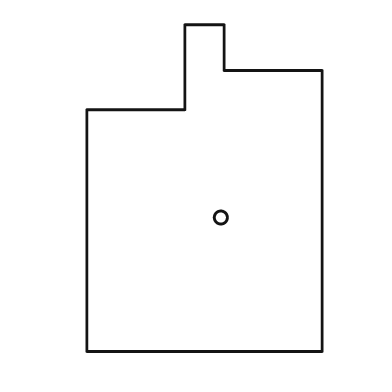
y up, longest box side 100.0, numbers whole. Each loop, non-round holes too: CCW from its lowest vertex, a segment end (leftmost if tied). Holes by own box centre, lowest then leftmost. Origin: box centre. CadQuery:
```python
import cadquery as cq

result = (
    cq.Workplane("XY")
    .moveTo(-36.0, -50.0)
    .lineTo(36.0, -50.0)
    .lineTo(36.0, 36.0)
    .lineTo(6.0, 36.0)
    .lineTo(6.0, 50.0)
    .lineTo(-6.0, 50.0)
    .lineTo(-6.0, 24.0)
    .lineTo(-36.0, 24.0)
    .close()
    .moveTo(5.0, -9.0)
    .circle(2.0)
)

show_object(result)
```